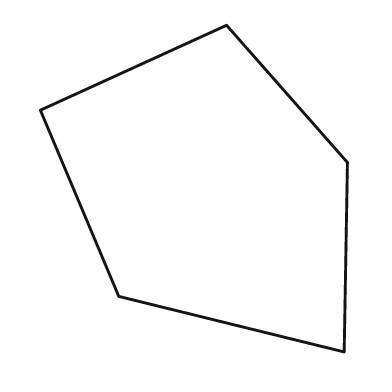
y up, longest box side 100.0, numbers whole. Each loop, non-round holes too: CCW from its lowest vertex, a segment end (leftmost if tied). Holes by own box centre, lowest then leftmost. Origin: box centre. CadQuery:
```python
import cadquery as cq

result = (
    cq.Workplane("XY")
    .moveTo(46.0, -50.0)
    .lineTo(47.0, 8.0)
    .lineTo(10.0, 50.0)
    .lineTo(-47.0, 24.0)
    .lineTo(-23.0, -33.0)
    .close()
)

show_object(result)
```